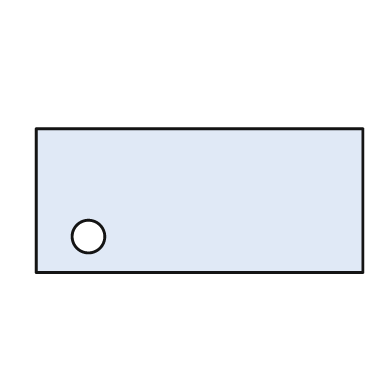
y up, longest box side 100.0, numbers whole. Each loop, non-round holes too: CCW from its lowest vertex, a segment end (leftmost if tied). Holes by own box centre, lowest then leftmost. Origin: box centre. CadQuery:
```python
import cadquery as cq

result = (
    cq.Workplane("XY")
    .moveTo(-50.0, -22.0)
    .lineTo(50.0, -22.0)
    .lineTo(50.0, 22.0)
    .lineTo(-50.0, 22.0)
    .close()
    .moveTo(-34.0, -11.0)
    .circle(5.0)
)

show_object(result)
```